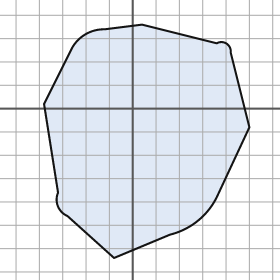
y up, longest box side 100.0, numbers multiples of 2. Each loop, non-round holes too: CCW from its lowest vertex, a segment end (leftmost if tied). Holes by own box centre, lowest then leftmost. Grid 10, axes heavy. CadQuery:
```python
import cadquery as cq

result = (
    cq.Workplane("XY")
    .moveTo(-8.0, -64.0)
    .lineTo(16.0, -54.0)
    .threePointArc((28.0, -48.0), (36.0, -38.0))
    .lineTo(50.0, -8.0)
    .lineTo(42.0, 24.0)
    .threePointArc((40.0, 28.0), (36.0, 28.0))
    .lineTo(4.0, 36.0)
    .lineTo(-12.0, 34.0)
    .threePointArc((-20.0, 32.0), (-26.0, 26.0))
    .lineTo(-38.0, 2.0)
    .lineTo(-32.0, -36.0)
    .threePointArc((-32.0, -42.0), (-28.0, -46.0))
    .close()
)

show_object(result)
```